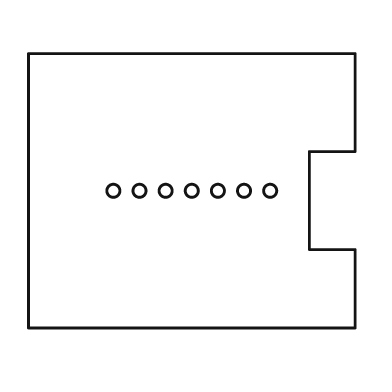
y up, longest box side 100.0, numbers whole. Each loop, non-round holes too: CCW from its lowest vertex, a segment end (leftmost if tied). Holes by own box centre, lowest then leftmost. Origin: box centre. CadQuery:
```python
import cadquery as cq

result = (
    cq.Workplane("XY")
    .moveTo(-50.0, -42.0)
    .lineTo(50.0, -42.0)
    .lineTo(50.0, -18.0)
    .lineTo(36.0, -18.0)
    .lineTo(36.0, 12.0)
    .lineTo(50.0, 12.0)
    .lineTo(50.0, 42.0)
    .lineTo(-50.0, 42.0)
    .close()
    .moveTo(-24.0, 0.0)
    .circle(2.0)
    .moveTo(-16.0, 0.0)
    .circle(2.0)
    .moveTo(-8.0, 0.0)
    .circle(2.0)
    .moveTo(0.0, 0.0)
    .circle(2.0)
    .moveTo(8.0, 0.0)
    .circle(2.0)
    .moveTo(16.0, 0.0)
    .circle(2.0)
    .moveTo(24.0, 0.0)
    .circle(2.0)
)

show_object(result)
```